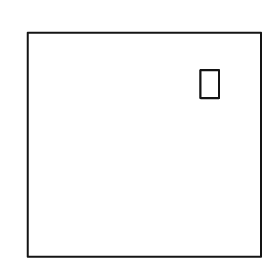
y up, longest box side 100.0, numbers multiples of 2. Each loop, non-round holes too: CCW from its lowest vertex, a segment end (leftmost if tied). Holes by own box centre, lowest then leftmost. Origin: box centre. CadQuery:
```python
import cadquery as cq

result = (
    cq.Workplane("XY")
    .moveTo(-50.0, -48.0)
    .lineTo(50.0, -48.0)
    .lineTo(50.0, 48.0)
    .lineTo(-50.0, 48.0)
    .close()
    .moveTo(24.0, 20.0)
    .lineTo(32.0, 20.0)
    .lineTo(32.0, 32.0)
    .lineTo(24.0, 32.0)
    .close()
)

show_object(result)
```